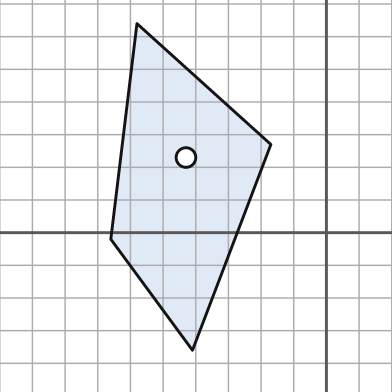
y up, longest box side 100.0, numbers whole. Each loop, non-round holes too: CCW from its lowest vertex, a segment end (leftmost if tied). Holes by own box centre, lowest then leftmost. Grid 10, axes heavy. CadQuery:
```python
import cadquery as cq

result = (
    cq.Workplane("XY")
    .moveTo(-41.0, -36.0)
    .lineTo(-17.0, 27.0)
    .lineTo(-58.0, 64.0)
    .lineTo(-66.0, -2.0)
    .close()
    .moveTo(-43.0, 23.0)
    .circle(3.0)
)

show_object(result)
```